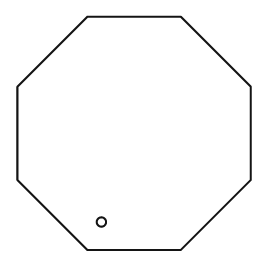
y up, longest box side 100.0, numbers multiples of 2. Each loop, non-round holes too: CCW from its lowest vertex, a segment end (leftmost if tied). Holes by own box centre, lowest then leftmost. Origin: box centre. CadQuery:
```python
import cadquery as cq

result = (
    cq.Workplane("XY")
    .moveTo(-20.0, -50.0)
    .lineTo(20.0, -50.0)
    .lineTo(50.0, -20.0)
    .lineTo(50.0, 20.0)
    .lineTo(20.0, 50.0)
    .lineTo(-20.0, 50.0)
    .lineTo(-50.0, 20.0)
    .lineTo(-50.0, -20.0)
    .close()
    .moveTo(-14.0, -38.0)
    .circle(2.0)
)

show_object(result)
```